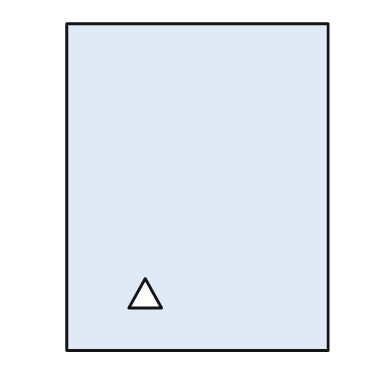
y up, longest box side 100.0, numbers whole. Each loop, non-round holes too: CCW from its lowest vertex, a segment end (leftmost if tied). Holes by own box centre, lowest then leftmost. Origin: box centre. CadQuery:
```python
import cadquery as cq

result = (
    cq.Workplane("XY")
    .moveTo(-40.0, -50.0)
    .lineTo(40.0, -50.0)
    .lineTo(40.0, 50.0)
    .lineTo(-40.0, 50.0)
    .close()
    .moveTo(-21.0, -37.0)
    .lineTo(-11.0, -37.0)
    .lineTo(-16.0, -28.0)
    .close()
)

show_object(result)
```